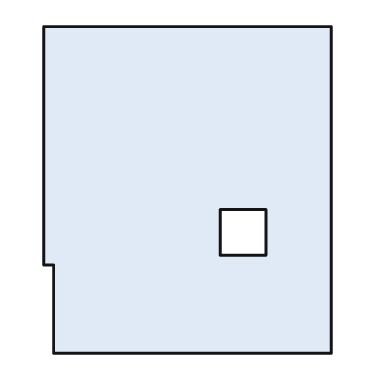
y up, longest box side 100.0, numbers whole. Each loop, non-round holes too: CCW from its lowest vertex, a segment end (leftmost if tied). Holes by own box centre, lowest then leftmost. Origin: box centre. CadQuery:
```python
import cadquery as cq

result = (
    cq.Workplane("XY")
    .moveTo(-41.0, -50.0)
    .lineTo(44.0, -50.0)
    .lineTo(44.0, 50.0)
    .lineTo(-44.0, 50.0)
    .lineTo(-44.0, -23.0)
    .lineTo(-41.0, -23.0)
    .close()
    .moveTo(10.0, -20.0)
    .lineTo(24.0, -20.0)
    .lineTo(24.0, -6.0)
    .lineTo(10.0, -6.0)
    .close()
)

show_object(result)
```